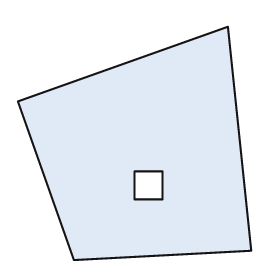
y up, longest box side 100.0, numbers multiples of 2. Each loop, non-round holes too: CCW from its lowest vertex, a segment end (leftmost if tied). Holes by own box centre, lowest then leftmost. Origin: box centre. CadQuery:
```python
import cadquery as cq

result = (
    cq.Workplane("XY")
    .moveTo(-26.0, -50.0)
    .lineTo(50.0, -46.0)
    .lineTo(40.0, 50.0)
    .lineTo(-50.0, 18.0)
    .close()
    .moveTo(0.0, -24.0)
    .lineTo(12.0, -24.0)
    .lineTo(12.0, -12.0)
    .lineTo(0.0, -12.0)
    .close()
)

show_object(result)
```